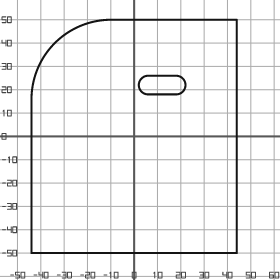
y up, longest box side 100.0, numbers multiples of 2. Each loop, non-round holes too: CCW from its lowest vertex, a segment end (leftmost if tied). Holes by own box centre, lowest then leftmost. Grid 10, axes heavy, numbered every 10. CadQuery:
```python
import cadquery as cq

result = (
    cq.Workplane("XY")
    .moveTo(-44.0, -50.0)
    .lineTo(44.0, -50.0)
    .lineTo(44.0, 50.0)
    .lineTo(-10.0, 50.0)
    .threePointArc((-34.0, 40.0), (-44.0, 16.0))
    .close()
    .moveTo(6.0, 18.0)
    .lineTo(18.0, 18.0)
    .threePointArc((22.0, 22.0), (18.0, 26.0))
    .lineTo(6.0, 26.0)
    .threePointArc((2.0, 22.0), (6.0, 18.0))
    .close()
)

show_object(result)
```